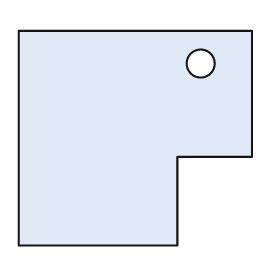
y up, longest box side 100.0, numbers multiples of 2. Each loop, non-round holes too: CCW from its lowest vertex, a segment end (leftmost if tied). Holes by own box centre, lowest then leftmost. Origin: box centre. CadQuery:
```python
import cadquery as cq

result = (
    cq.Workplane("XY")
    .moveTo(-50.0, -46.0)
    .lineTo(18.0, -46.0)
    .lineTo(18.0, -8.0)
    .lineTo(50.0, -8.0)
    .lineTo(50.0, 46.0)
    .lineTo(-50.0, 46.0)
    .close()
    .moveTo(28.0, 32.0)
    .circle(6.0)
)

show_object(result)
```